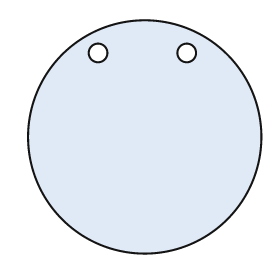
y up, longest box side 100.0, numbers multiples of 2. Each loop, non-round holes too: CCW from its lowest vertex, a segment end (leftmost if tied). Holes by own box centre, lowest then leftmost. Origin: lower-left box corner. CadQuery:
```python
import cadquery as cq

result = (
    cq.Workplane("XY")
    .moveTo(50.0, 50.0)
    .circle(50.0)
    .moveTo(30.0, 86.0)
    .circle(4.0)
    .moveTo(68.0, 86.0)
    .circle(4.0)
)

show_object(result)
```